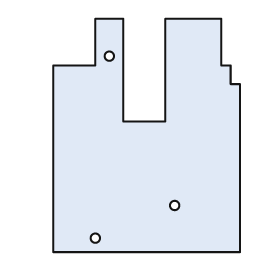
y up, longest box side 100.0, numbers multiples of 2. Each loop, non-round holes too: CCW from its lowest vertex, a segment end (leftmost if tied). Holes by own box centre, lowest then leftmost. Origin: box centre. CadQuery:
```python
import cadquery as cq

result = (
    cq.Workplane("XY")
    .moveTo(-40.0, -50.0)
    .lineTo(40.0, -50.0)
    .lineTo(40.0, 22.0)
    .lineTo(36.0, 22.0)
    .lineTo(36.0, 30.0)
    .lineTo(32.0, 30.0)
    .lineTo(32.0, 50.0)
    .lineTo(8.0, 50.0)
    .lineTo(8.0, 6.0)
    .lineTo(-10.0, 6.0)
    .lineTo(-10.0, 50.0)
    .lineTo(-22.0, 50.0)
    .lineTo(-22.0, 30.0)
    .lineTo(-40.0, 30.0)
    .close()
    .moveTo(-22.0, -44.0)
    .circle(2.0)
    .moveTo(12.0, -30.0)
    .circle(2.0)
    .moveTo(-16.0, 34.0)
    .circle(2.0)
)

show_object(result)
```